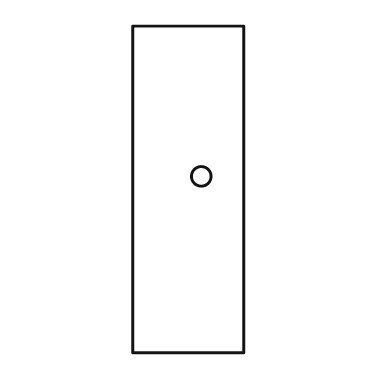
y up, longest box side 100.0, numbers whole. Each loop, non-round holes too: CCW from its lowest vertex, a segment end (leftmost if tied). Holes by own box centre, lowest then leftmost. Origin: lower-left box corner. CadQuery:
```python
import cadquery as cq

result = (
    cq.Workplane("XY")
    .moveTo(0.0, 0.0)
    .lineTo(34.0, 0.0)
    .lineTo(34.0, 100.0)
    .lineTo(0.0, 100.0)
    .close()
    .moveTo(21.0, 54.0)
    .circle(3.0)
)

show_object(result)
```